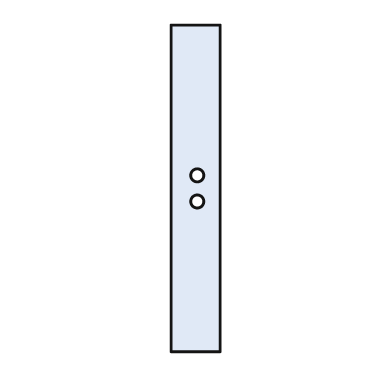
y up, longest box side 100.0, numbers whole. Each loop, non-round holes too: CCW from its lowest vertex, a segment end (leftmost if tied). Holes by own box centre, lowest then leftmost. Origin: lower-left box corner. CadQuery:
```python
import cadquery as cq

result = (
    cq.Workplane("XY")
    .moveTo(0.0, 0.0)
    .lineTo(15.0, 0.0)
    .lineTo(15.0, 100.0)
    .lineTo(0.0, 100.0)
    .close()
    .moveTo(8.0, 46.0)
    .circle(2.0)
    .moveTo(8.0, 54.0)
    .circle(2.0)
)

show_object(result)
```